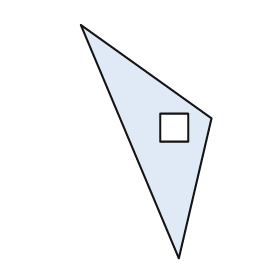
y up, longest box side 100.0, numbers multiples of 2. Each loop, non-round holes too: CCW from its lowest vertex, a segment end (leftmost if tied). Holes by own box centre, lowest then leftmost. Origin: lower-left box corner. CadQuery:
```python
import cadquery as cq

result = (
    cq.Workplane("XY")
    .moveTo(42.0, 0.0)
    .lineTo(56.0, 60.0)
    .lineTo(0.0, 100.0)
    .close()
    .moveTo(34.0, 50.0)
    .lineTo(46.0, 50.0)
    .lineTo(46.0, 62.0)
    .lineTo(34.0, 62.0)
    .close()
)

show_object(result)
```